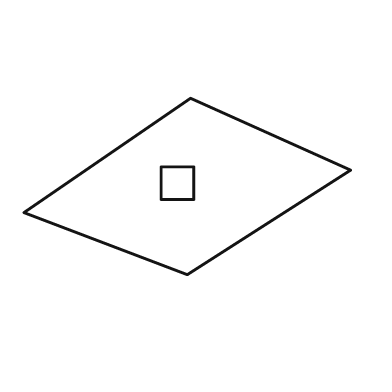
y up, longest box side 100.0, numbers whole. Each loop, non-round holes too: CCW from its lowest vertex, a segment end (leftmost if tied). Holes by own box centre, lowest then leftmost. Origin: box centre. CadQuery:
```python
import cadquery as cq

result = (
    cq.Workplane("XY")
    .moveTo(0.0, -27.0)
    .lineTo(50.0, 5.0)
    .lineTo(1.0, 27.0)
    .lineTo(-50.0, -8.0)
    .close()
    .moveTo(-8.0, -4.0)
    .lineTo(2.0, -4.0)
    .lineTo(2.0, 6.0)
    .lineTo(-8.0, 6.0)
    .close()
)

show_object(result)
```